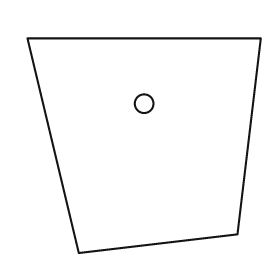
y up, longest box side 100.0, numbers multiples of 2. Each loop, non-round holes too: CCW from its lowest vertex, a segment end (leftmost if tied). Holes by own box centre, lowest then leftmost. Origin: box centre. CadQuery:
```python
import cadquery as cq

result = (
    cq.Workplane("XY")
    .moveTo(-28.0, -46.0)
    .lineTo(40.0, -38.0)
    .lineTo(50.0, 46.0)
    .lineTo(-50.0, 46.0)
    .close()
    .moveTo(0.0, 18.0)
    .circle(4.0)
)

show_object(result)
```